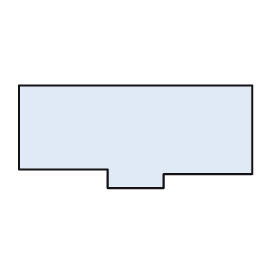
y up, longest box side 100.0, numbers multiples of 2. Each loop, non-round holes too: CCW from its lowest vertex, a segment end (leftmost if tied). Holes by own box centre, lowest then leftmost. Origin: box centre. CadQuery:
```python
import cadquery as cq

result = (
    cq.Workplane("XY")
    .moveTo(-12.0, -22.0)
    .lineTo(12.0, -22.0)
    .lineTo(12.0, -16.0)
    .lineTo(50.0, -16.0)
    .lineTo(50.0, 22.0)
    .lineTo(-50.0, 22.0)
    .lineTo(-50.0, -14.0)
    .lineTo(-12.0, -14.0)
    .close()
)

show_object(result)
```